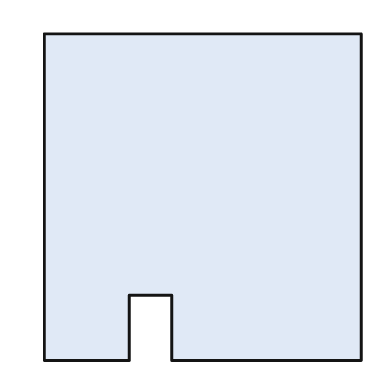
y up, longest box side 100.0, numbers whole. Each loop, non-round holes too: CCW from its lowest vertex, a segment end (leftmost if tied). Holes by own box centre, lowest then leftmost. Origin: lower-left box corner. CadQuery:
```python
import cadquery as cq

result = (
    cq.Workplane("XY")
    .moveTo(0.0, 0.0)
    .lineTo(26.0, 0.0)
    .lineTo(26.0, 20.0)
    .lineTo(39.0, 20.0)
    .lineTo(39.0, 0.0)
    .lineTo(97.0, 0.0)
    .lineTo(97.0, 100.0)
    .lineTo(0.0, 100.0)
    .close()
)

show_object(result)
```